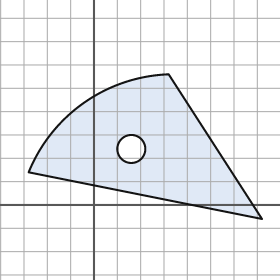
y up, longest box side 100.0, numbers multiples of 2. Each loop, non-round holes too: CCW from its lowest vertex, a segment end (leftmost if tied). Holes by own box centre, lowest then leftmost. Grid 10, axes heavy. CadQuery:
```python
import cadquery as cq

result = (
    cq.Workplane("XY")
    .moveTo(72.0, -6.0)
    .lineTo(32.0, 56.0)
    .threePointArc((-4.0, 44.0), (-28.0, 14.0))
    .close()
    .moveTo(16.0, 24.0)
    .circle(6.0)
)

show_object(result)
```